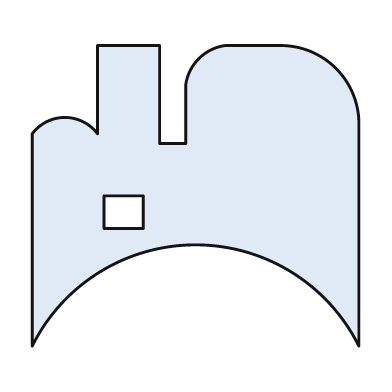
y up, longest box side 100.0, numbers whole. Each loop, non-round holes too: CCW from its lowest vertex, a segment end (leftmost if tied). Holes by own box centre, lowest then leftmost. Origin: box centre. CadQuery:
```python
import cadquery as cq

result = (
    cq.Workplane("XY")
    .moveTo(-50.0, -46.0)
    .threePointArc((0.0, -15.0), (50.0, -46.0))
    .lineTo(50.0, 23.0)
    .threePointArc((43.0, 39.0), (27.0, 46.0))
    .lineTo(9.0, 46.0)
    .threePointArc((1.0, 42.0), (-3.0, 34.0))
    .lineTo(-3.0, 16.0)
    .lineTo(-11.0, 16.0)
    .lineTo(-11.0, 46.0)
    .lineTo(-30.0, 46.0)
    .lineTo(-30.0, 19.0)
    .threePointArc((-40.0, 24.0), (-50.0, 19.0))
    .close()
    .moveTo(-28.0, -10.0)
    .lineTo(-16.0, -10.0)
    .lineTo(-16.0, 0.0)
    .lineTo(-28.0, 0.0)
    .close()
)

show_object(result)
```